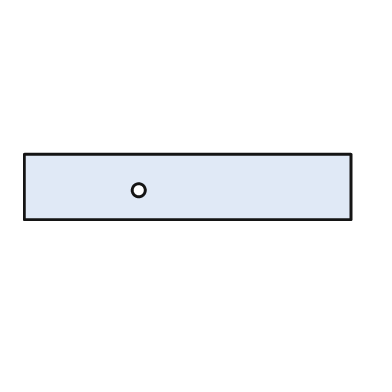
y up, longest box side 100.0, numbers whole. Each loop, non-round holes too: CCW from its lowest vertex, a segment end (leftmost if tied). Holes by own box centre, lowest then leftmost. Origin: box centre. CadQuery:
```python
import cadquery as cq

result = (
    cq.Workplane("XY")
    .moveTo(-50.0, -10.0)
    .lineTo(50.0, -10.0)
    .lineTo(50.0, 10.0)
    .lineTo(-50.0, 10.0)
    .close()
    .moveTo(-15.0, -1.0)
    .circle(2.0)
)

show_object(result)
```